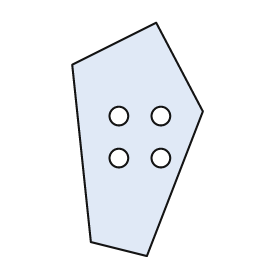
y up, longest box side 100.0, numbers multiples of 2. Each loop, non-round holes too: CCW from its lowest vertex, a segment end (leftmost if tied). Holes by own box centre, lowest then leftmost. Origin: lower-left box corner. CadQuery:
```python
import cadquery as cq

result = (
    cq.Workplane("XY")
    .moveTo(32.0, 0.0)
    .lineTo(56.0, 62.0)
    .lineTo(36.0, 100.0)
    .lineTo(0.0, 82.0)
    .lineTo(8.0, 6.0)
    .close()
    .moveTo(20.0, 42.0)
    .circle(4.0)
    .moveTo(38.0, 42.0)
    .circle(4.0)
    .moveTo(20.0, 60.0)
    .circle(4.0)
    .moveTo(38.0, 60.0)
    .circle(4.0)
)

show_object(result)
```